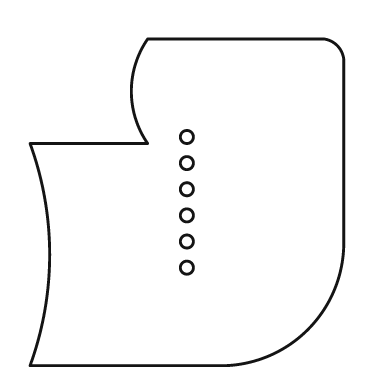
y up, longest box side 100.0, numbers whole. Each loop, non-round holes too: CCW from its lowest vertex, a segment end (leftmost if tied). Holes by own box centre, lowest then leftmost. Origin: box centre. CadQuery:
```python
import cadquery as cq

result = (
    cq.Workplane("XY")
    .moveTo(-48.0, -50.0)
    .lineTo(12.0, -50.0)
    .threePointArc((37.0, -39.0), (48.0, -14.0))
    .lineTo(48.0, 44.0)
    .threePointArc((46.0, 48.0), (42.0, 50.0))
    .lineTo(-12.0, 50.0)
    .threePointArc((-17.0, 34.0), (-12.0, 18.0))
    .lineTo(-48.0, 18.0)
    .threePointArc((-42.0, -16.0), (-48.0, -50.0))
    .close()
    .moveTo(0.0, -20.0)
    .circle(2.0)
    .moveTo(0.0, -12.0)
    .circle(2.0)
    .moveTo(0.0, -4.0)
    .circle(2.0)
    .moveTo(0.0, 4.0)
    .circle(2.0)
    .moveTo(0.0, 12.0)
    .circle(2.0)
    .moveTo(0.0, 20.0)
    .circle(2.0)
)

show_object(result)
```